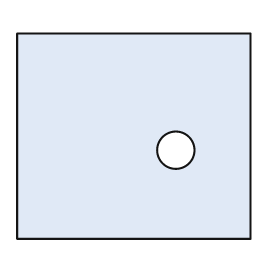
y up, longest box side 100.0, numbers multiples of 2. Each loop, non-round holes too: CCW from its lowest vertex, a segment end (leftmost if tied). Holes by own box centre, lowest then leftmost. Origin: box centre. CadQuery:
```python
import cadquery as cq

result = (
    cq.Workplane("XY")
    .moveTo(-50.0, -44.0)
    .lineTo(50.0, -44.0)
    .lineTo(50.0, 44.0)
    .lineTo(-50.0, 44.0)
    .close()
    .moveTo(18.0, -6.0)
    .circle(8.0)
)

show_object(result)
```